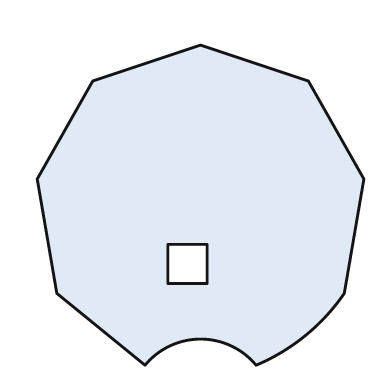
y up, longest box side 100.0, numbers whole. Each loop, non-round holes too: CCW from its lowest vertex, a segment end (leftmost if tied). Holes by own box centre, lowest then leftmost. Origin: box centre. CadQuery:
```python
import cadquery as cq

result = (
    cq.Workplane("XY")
    .moveTo(-17.0, -49.0)
    .threePointArc((0.0, -41.0), (17.0, -49.0))
    .threePointArc((32.0, -40.0), (44.0, -27.0))
    .lineTo(50.0, 8.0)
    .lineTo(33.0, 38.0)
    .lineTo(0.0, 49.0)
    .lineTo(-33.0, 38.0)
    .lineTo(-50.0, 8.0)
    .lineTo(-44.0, -27.0)
    .close()
    .moveTo(-10.0, -24.0)
    .lineTo(2.0, -24.0)
    .lineTo(2.0, -12.0)
    .lineTo(-10.0, -12.0)
    .close()
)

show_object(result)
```